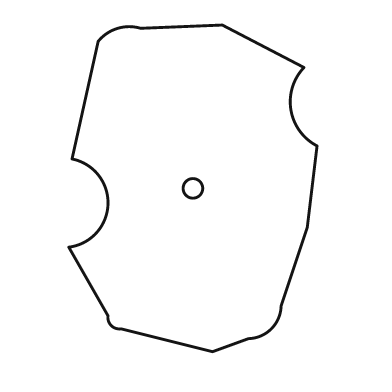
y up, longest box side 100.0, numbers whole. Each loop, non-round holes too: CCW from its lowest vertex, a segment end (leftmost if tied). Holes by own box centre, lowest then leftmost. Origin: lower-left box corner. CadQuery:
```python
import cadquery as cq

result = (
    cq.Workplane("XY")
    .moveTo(44.0, 0.0)
    .lineTo(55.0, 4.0)
    .threePointArc((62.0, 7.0), (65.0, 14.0))
    .lineTo(73.0, 38.0)
    .lineTo(76.0, 63.0)
    .threePointArc((68.0, 74.0), (72.0, 87.0))
    .lineTo(47.0, 100.0)
    .lineTo(22.0, 99.0)
    .threePointArc((15.0, 99.0), (9.0, 95.0))
    .lineTo(1.0, 59.0)
    .threePointArc((12.0, 45.0), (0.0, 32.0))
    .lineTo(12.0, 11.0)
    .threePointArc((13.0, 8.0), (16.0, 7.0))
    .close()
    .moveTo(38.0, 50.0)
    .circle(3.0)
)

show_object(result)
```